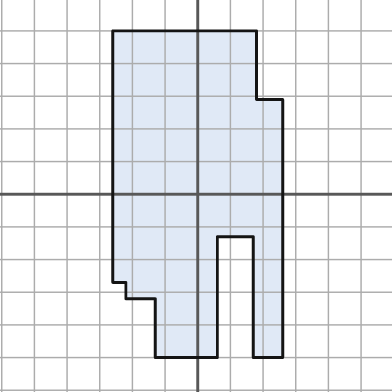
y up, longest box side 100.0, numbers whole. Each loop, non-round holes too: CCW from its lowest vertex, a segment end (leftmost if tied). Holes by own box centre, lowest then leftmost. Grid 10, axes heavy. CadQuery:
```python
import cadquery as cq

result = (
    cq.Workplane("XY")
    .moveTo(-13.0, -50.0)
    .lineTo(6.0, -50.0)
    .lineTo(6.0, -13.0)
    .lineTo(17.0, -13.0)
    .lineTo(17.0, -50.0)
    .lineTo(26.0, -50.0)
    .lineTo(26.0, 29.0)
    .lineTo(18.0, 29.0)
    .lineTo(18.0, 50.0)
    .lineTo(-26.0, 50.0)
    .lineTo(-26.0, -27.0)
    .lineTo(-22.0, -27.0)
    .lineTo(-22.0, -32.0)
    .lineTo(-13.0, -32.0)
    .close()
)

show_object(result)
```